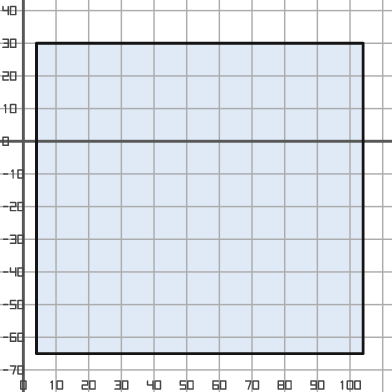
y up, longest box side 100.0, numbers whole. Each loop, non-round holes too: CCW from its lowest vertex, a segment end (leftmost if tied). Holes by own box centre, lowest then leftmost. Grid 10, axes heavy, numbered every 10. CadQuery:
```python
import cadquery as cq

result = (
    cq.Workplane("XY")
    .moveTo(4.0, -65.0)
    .lineTo(104.0, -65.0)
    .lineTo(104.0, 30.0)
    .lineTo(4.0, 30.0)
    .close()
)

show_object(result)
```